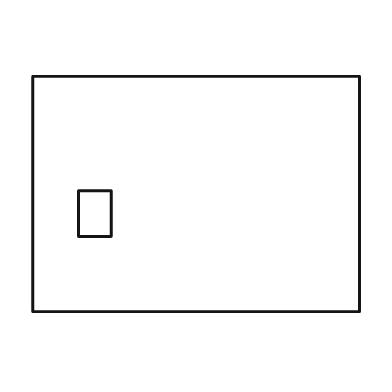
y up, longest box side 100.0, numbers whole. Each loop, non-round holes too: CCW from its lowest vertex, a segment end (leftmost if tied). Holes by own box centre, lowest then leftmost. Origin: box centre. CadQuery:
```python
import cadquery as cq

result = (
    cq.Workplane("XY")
    .moveTo(-50.0, -36.0)
    .lineTo(50.0, -36.0)
    .lineTo(50.0, 36.0)
    .lineTo(-50.0, 36.0)
    .close()
    .moveTo(-36.0, -13.0)
    .lineTo(-26.0, -13.0)
    .lineTo(-26.0, 1.0)
    .lineTo(-36.0, 1.0)
    .close()
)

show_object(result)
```